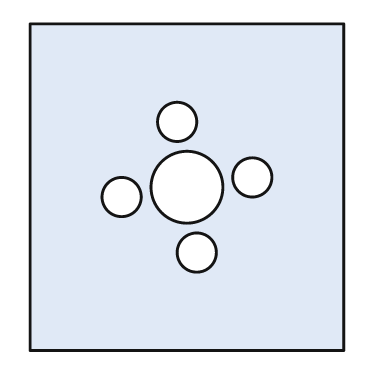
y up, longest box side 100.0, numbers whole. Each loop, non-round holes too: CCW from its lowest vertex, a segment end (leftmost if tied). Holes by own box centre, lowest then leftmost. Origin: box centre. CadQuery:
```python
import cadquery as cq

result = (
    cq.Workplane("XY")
    .moveTo(-48.0, -50.0)
    .lineTo(48.0, -50.0)
    .lineTo(48.0, 50.0)
    .lineTo(-48.0, 50.0)
    .close()
    .moveTo(3.0, -20.0)
    .circle(6.0)
    .moveTo(-20.0, -3.0)
    .circle(6.0)
    .moveTo(0.0, 0.0)
    .circle(11.0)
    .moveTo(20.0, 3.0)
    .circle(6.0)
    .moveTo(-3.0, 20.0)
    .circle(6.0)
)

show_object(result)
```